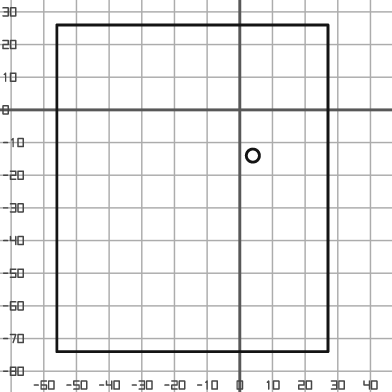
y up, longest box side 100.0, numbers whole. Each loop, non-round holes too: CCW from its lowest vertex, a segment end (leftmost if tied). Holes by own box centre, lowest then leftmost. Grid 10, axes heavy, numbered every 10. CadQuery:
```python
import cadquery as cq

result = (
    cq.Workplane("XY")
    .moveTo(-56.0, -74.0)
    .lineTo(27.0, -74.0)
    .lineTo(27.0, 26.0)
    .lineTo(-56.0, 26.0)
    .close()
    .moveTo(4.0, -14.0)
    .circle(2.0)
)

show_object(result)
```